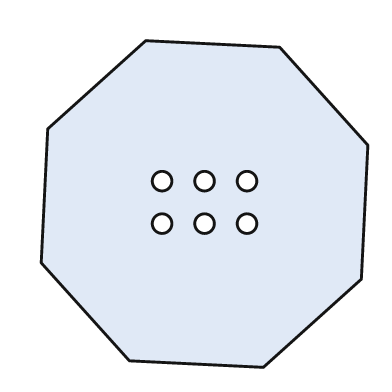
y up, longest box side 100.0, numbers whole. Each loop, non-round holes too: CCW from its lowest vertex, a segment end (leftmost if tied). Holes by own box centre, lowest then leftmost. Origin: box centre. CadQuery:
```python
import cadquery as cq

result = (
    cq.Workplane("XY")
    .moveTo(18.0, -50.0)
    .lineTo(48.0, -23.0)
    .lineTo(50.0, 18.0)
    .lineTo(23.0, 48.0)
    .lineTo(-18.0, 50.0)
    .lineTo(-48.0, 23.0)
    .lineTo(-50.0, -18.0)
    .lineTo(-23.0, -48.0)
    .close()
    .moveTo(-13.0, -6.0)
    .circle(3.0)
    .moveTo(0.0, -6.0)
    .circle(3.0)
    .moveTo(13.0, -6.0)
    .circle(3.0)
    .moveTo(-13.0, 7.0)
    .circle(3.0)
    .moveTo(0.0, 7.0)
    .circle(3.0)
    .moveTo(13.0, 7.0)
    .circle(3.0)
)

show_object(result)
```